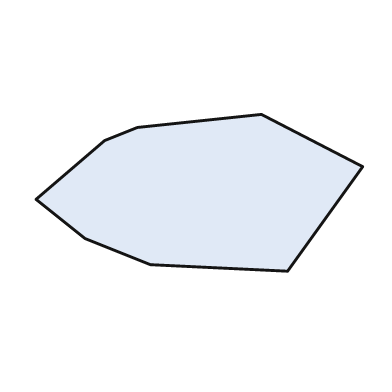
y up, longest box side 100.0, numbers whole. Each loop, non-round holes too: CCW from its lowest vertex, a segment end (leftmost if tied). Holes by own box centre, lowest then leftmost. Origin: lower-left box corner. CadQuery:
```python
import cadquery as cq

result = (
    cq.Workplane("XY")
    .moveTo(77.0, 0.0)
    .lineTo(100.0, 32.0)
    .lineTo(69.0, 48.0)
    .lineTo(31.0, 44.0)
    .lineTo(21.0, 40.0)
    .lineTo(0.0, 22.0)
    .lineTo(15.0, 10.0)
    .lineTo(35.0, 2.0)
    .close()
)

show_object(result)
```